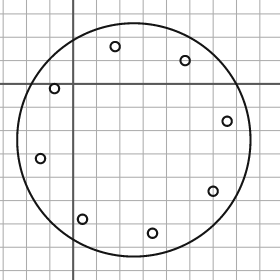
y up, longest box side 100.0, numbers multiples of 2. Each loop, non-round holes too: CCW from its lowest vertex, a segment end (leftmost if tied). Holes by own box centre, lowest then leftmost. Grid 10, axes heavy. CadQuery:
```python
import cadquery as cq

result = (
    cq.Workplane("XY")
    .moveTo(26.0, -24.0)
    .circle(50.0)
    .moveTo(34.0, -64.0)
    .circle(2.0)
    .moveTo(4.0, -58.0)
    .circle(2.0)
    .moveTo(60.0, -46.0)
    .circle(2.0)
    .moveTo(-14.0, -32.0)
    .circle(2.0)
    .moveTo(66.0, -16.0)
    .circle(2.0)
    .moveTo(-8.0, -2.0)
    .circle(2.0)
    .moveTo(48.0, 10.0)
    .circle(2.0)
    .moveTo(18.0, 16.0)
    .circle(2.0)
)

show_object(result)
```